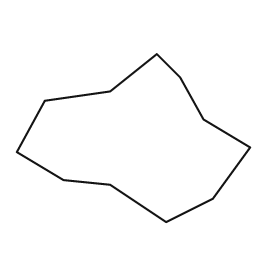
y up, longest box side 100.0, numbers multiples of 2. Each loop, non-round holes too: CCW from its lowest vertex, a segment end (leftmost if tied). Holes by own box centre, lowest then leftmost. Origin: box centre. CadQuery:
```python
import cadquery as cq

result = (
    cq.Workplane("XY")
    .moveTo(14.0, -36.0)
    .lineTo(34.0, -26.0)
    .lineTo(50.0, -4.0)
    .lineTo(30.0, 8.0)
    .lineTo(20.0, 26.0)
    .lineTo(10.0, 36.0)
    .lineTo(-10.0, 20.0)
    .lineTo(-38.0, 16.0)
    .lineTo(-50.0, -6.0)
    .lineTo(-30.0, -18.0)
    .lineTo(-10.0, -20.0)
    .close()
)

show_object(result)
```